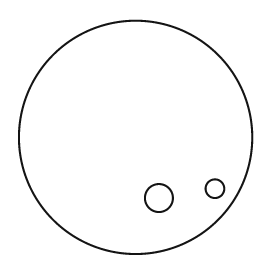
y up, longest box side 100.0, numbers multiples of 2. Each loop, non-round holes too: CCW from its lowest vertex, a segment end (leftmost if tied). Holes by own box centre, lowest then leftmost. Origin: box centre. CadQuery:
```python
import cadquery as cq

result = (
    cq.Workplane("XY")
    .moveTo(0.0, 0.0)
    .circle(50.0)
    .moveTo(10.0, -26.0)
    .circle(6.0)
    .moveTo(34.0, -22.0)
    .circle(4.0)
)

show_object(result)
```